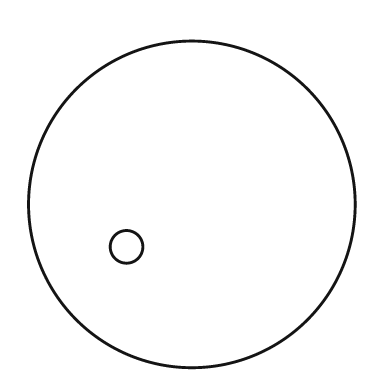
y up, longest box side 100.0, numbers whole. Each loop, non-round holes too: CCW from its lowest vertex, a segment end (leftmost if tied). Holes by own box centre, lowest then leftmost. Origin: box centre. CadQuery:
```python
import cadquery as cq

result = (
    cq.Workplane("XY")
    .moveTo(0.0, 0.0)
    .circle(50.0)
    .moveTo(-20.0, -13.0)
    .circle(5.0)
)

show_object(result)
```